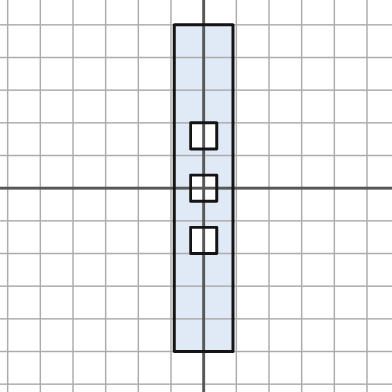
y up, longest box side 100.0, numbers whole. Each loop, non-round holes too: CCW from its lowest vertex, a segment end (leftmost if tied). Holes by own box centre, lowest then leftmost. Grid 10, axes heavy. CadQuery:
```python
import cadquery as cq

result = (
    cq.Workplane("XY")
    .moveTo(-9.0, -50.0)
    .lineTo(9.0, -50.0)
    .lineTo(9.0, 50.0)
    .lineTo(-9.0, 50.0)
    .close()
    .moveTo(-4.0, -20.0)
    .lineTo(4.0, -20.0)
    .lineTo(4.0, -12.0)
    .lineTo(-4.0, -12.0)
    .close()
    .moveTo(-4.0, -4.0)
    .lineTo(4.0, -4.0)
    .lineTo(4.0, 4.0)
    .lineTo(-4.0, 4.0)
    .close()
    .moveTo(-4.0, 12.0)
    .lineTo(4.0, 12.0)
    .lineTo(4.0, 20.0)
    .lineTo(-4.0, 20.0)
    .close()
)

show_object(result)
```